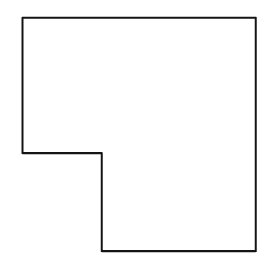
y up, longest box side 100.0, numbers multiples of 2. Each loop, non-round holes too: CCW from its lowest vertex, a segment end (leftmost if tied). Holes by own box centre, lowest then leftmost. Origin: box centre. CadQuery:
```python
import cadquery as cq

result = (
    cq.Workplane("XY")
    .moveTo(-16.0, -50.0)
    .lineTo(50.0, -50.0)
    .lineTo(50.0, 50.0)
    .lineTo(-50.0, 50.0)
    .lineTo(-50.0, -8.0)
    .lineTo(-16.0, -8.0)
    .close()
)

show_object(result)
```